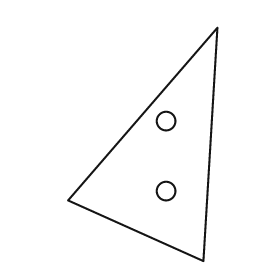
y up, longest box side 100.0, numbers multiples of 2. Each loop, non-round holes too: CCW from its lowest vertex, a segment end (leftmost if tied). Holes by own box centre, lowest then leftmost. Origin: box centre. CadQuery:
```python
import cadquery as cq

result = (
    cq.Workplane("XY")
    .moveTo(26.0, -50.0)
    .lineTo(32.0, 50.0)
    .lineTo(-32.0, -24.0)
    .close()
    .moveTo(10.0, -20.0)
    .circle(4.0)
    .moveTo(10.0, 10.0)
    .circle(4.0)
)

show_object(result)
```